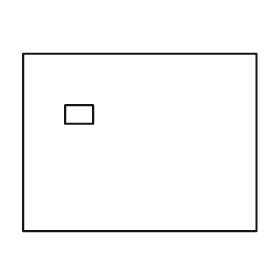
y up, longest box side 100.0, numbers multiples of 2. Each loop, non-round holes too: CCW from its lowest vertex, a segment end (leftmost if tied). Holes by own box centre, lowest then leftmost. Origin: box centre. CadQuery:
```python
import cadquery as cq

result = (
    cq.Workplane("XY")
    .moveTo(-50.0, -38.0)
    .lineTo(50.0, -38.0)
    .lineTo(50.0, 38.0)
    .lineTo(-50.0, 38.0)
    .close()
    .moveTo(-32.0, 8.0)
    .lineTo(-20.0, 8.0)
    .lineTo(-20.0, 16.0)
    .lineTo(-32.0, 16.0)
    .close()
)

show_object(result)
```